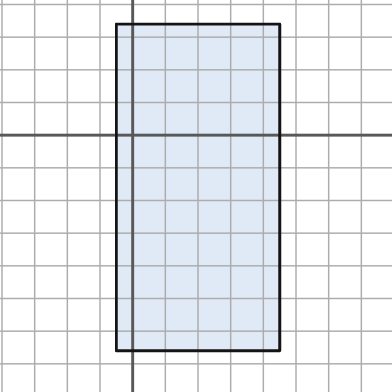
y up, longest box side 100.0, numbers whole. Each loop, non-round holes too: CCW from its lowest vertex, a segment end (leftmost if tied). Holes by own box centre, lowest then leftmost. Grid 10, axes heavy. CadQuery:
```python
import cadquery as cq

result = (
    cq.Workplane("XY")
    .moveTo(-5.0, -66.0)
    .lineTo(45.0, -66.0)
    .lineTo(45.0, 34.0)
    .lineTo(-5.0, 34.0)
    .close()
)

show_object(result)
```